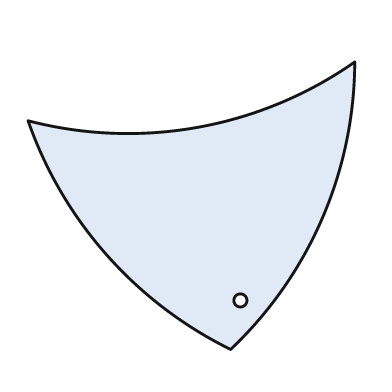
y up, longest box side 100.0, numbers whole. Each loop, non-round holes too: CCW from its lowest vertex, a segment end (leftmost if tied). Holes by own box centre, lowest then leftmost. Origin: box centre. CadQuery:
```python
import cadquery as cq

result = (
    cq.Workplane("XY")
    .moveTo(12.0, -44.0)
    .threePointArc((40.0, -4.0), (50.0, 44.0))
    .threePointArc((2.0, 24.0), (-50.0, 26.0))
    .threePointArc((-26.0, -15.0), (12.0, -44.0))
    .close()
    .moveTo(15.0, -29.0)
    .circle(2.0)
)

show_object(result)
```